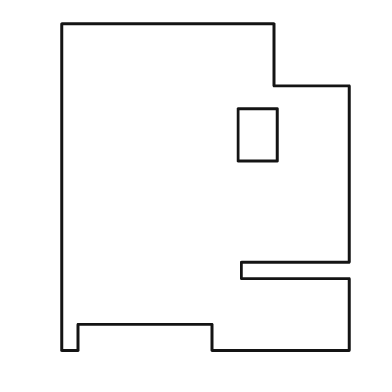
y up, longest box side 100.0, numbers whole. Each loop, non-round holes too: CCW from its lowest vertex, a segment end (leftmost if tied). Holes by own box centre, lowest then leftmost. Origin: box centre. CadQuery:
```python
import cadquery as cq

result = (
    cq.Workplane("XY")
    .moveTo(-44.0, -50.0)
    .lineTo(-39.0, -50.0)
    .lineTo(-39.0, -42.0)
    .lineTo(2.0, -42.0)
    .lineTo(2.0, -50.0)
    .lineTo(44.0, -50.0)
    .lineTo(44.0, -28.0)
    .lineTo(11.0, -28.0)
    .lineTo(11.0, -23.0)
    .lineTo(44.0, -23.0)
    .lineTo(44.0, 31.0)
    .lineTo(21.0, 31.0)
    .lineTo(21.0, 50.0)
    .lineTo(-44.0, 50.0)
    .close()
    .moveTo(10.0, 8.0)
    .lineTo(22.0, 8.0)
    .lineTo(22.0, 24.0)
    .lineTo(10.0, 24.0)
    .close()
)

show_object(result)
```